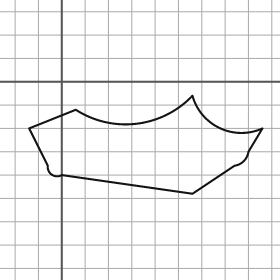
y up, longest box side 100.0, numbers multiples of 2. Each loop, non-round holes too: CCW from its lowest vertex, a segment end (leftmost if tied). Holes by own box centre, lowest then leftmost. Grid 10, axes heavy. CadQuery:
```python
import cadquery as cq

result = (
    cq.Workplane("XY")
    .moveTo(56.0, -48.0)
    .lineTo(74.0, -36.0)
    .threePointArc((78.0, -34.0), (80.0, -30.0))
    .lineTo(86.0, -20.0)
    .threePointArc((68.0, -20.0), (56.0, -6.0))
    .threePointArc((32.0, -18.0), (6.0, -12.0))
    .lineTo(-14.0, -20.0)
    .lineTo(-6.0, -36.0)
    .threePointArc((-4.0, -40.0), (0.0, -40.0))
    .close()
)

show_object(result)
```